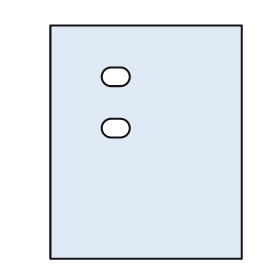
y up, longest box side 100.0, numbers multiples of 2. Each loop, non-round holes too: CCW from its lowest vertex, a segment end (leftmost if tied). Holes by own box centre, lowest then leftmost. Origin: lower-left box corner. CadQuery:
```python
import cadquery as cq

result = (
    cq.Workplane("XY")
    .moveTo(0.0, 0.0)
    .lineTo(82.0, 0.0)
    .lineTo(82.0, 100.0)
    .lineTo(0.0, 100.0)
    .close()
    .moveTo(26.0, 52.0)
    .lineTo(30.0, 52.0)
    .threePointArc((34.0, 56.0), (30.0, 60.0))
    .lineTo(26.0, 60.0)
    .threePointArc((22.0, 56.0), (26.0, 52.0))
    .close()
    .moveTo(26.0, 74.0)
    .lineTo(30.0, 74.0)
    .threePointArc((34.0, 78.0), (30.0, 82.0))
    .lineTo(26.0, 82.0)
    .threePointArc((22.0, 78.0), (26.0, 74.0))
    .close()
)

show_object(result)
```